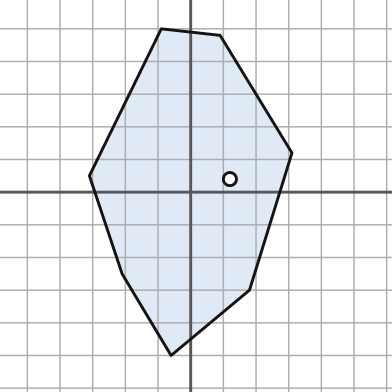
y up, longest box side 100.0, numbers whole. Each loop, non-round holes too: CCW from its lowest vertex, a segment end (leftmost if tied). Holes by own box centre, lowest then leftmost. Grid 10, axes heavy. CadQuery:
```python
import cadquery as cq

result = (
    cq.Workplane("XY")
    .moveTo(-6.0, -50.0)
    .lineTo(18.0, -30.0)
    .lineTo(31.0, 12.0)
    .lineTo(9.0, 48.0)
    .lineTo(-9.0, 50.0)
    .lineTo(-31.0, 5.0)
    .lineTo(-21.0, -25.0)
    .close()
    .moveTo(12.0, 4.0)
    .circle(2.0)
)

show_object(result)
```